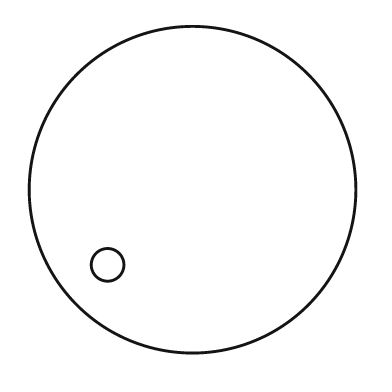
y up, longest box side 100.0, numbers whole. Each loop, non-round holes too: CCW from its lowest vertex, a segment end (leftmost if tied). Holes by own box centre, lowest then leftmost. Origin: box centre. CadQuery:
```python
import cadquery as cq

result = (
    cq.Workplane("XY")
    .moveTo(0.0, 0.0)
    .circle(50.0)
    .moveTo(-26.0, -23.0)
    .circle(5.0)
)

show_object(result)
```